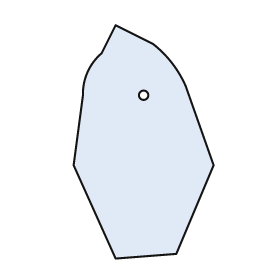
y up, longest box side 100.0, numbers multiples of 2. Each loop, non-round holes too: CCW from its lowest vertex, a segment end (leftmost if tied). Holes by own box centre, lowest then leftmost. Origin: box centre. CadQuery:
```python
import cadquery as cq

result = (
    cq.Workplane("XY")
    .moveTo(-12.0, -50.0)
    .lineTo(14.0, -48.0)
    .lineTo(30.0, -10.0)
    .lineTo(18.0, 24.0)
    .threePointArc((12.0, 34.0), (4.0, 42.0))
    .lineTo(-12.0, 50.0)
    .lineTo(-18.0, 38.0)
    .threePointArc((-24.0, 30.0), (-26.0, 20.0))
    .lineTo(-30.0, -10.0)
    .close()
    .moveTo(0.0, 20.0)
    .circle(2.0)
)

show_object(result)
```